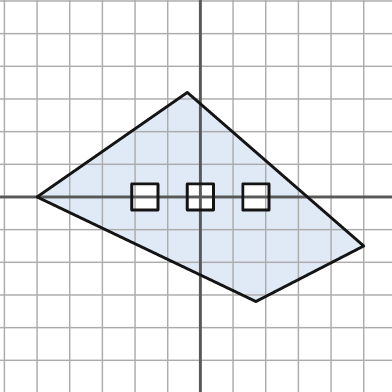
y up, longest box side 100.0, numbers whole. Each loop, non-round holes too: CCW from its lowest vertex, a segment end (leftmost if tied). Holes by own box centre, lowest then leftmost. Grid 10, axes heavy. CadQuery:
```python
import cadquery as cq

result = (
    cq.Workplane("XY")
    .moveTo(17.0, -32.0)
    .lineTo(50.0, -15.0)
    .lineTo(-4.0, 32.0)
    .lineTo(-50.0, 0.0)
    .close()
    .moveTo(-21.0, -4.0)
    .lineTo(-13.0, -4.0)
    .lineTo(-13.0, 4.0)
    .lineTo(-21.0, 4.0)
    .close()
    .moveTo(-4.0, -4.0)
    .lineTo(4.0, -4.0)
    .lineTo(4.0, 4.0)
    .lineTo(-4.0, 4.0)
    .close()
    .moveTo(13.0, -4.0)
    .lineTo(21.0, -4.0)
    .lineTo(21.0, 4.0)
    .lineTo(13.0, 4.0)
    .close()
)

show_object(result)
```